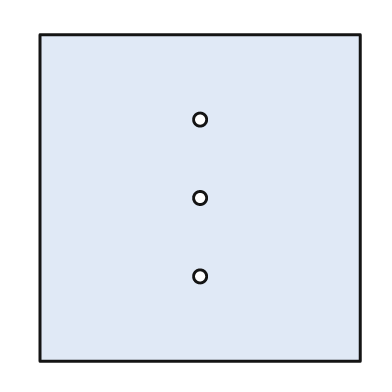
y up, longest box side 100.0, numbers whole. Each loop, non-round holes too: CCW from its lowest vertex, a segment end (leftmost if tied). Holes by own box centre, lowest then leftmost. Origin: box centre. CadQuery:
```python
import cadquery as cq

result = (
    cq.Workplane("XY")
    .moveTo(-49.0, -50.0)
    .lineTo(49.0, -50.0)
    .lineTo(49.0, 50.0)
    .lineTo(-49.0, 50.0)
    .close()
    .moveTo(0.0, -24.0)
    .circle(2.0)
    .moveTo(0.0, 0.0)
    .circle(2.0)
    .moveTo(0.0, 24.0)
    .circle(2.0)
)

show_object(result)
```